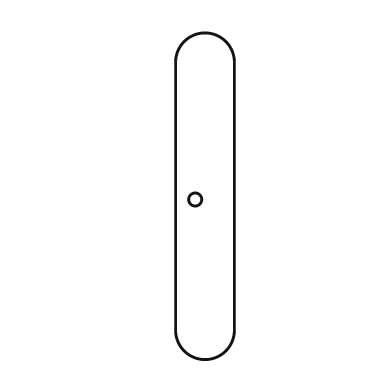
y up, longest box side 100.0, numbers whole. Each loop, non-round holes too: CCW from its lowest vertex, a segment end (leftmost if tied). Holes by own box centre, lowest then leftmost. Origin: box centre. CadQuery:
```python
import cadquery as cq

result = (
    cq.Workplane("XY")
    .moveTo(-9.0, -41.0)
    .threePointArc((0.0, -50.0), (9.0, -41.0))
    .lineTo(9.0, 41.0)
    .threePointArc((0.0, 50.0), (-9.0, 41.0))
    .close()
    .moveTo(-3.0, -1.0)
    .circle(2.0)
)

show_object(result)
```